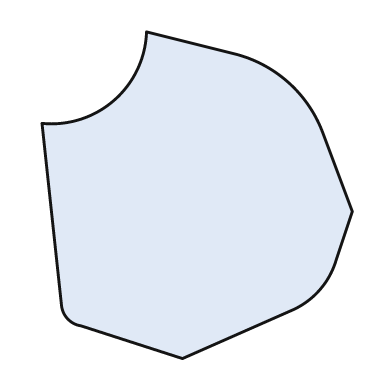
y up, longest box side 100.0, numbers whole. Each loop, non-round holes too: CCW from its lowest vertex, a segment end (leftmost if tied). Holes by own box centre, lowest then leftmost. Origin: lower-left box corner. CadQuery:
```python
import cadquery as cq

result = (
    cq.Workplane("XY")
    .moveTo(43.0, 0.0)
    .lineTo(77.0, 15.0)
    .threePointArc((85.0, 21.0), (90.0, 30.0))
    .lineTo(95.0, 45.0)
    .lineTo(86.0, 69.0)
    .threePointArc((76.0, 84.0), (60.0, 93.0))
    .lineTo(32.0, 100.0)
    .threePointArc((22.0, 79.0), (0.0, 72.0))
    .lineTo(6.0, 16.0)
    .threePointArc((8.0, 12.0), (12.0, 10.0))
    .close()
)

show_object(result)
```